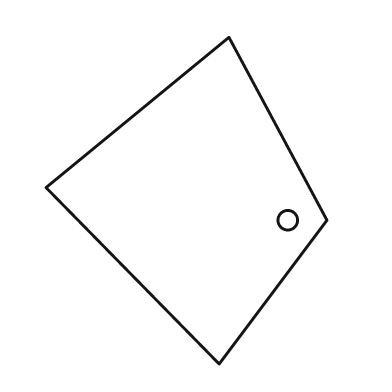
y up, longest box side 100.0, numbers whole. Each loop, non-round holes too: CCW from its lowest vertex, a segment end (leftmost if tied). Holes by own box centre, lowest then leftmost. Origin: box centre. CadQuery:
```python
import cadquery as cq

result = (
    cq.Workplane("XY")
    .moveTo(10.0, -50.0)
    .lineTo(43.0, -6.0)
    .lineTo(13.0, 50.0)
    .lineTo(-43.0, 4.0)
    .close()
    .moveTo(31.0, -6.0)
    .circle(3.0)
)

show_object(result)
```